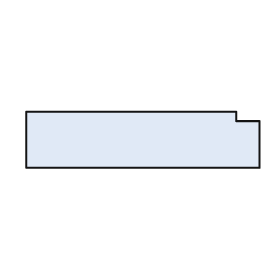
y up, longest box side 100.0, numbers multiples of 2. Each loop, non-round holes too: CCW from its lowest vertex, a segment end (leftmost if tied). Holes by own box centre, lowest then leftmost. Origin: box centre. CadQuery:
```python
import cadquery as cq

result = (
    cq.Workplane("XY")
    .moveTo(-50.0, -12.0)
    .lineTo(50.0, -12.0)
    .lineTo(50.0, 8.0)
    .lineTo(40.0, 8.0)
    .lineTo(40.0, 12.0)
    .lineTo(-50.0, 12.0)
    .close()
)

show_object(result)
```